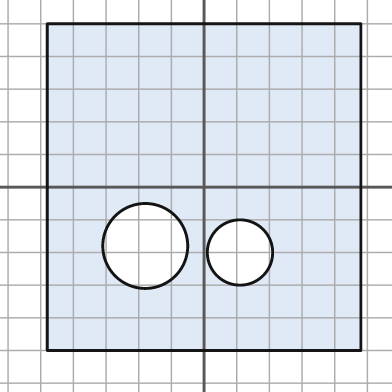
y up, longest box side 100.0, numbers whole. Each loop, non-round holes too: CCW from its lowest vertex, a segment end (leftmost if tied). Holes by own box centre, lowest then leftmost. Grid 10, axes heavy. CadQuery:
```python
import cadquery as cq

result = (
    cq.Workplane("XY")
    .moveTo(-48.0, -50.0)
    .lineTo(48.0, -50.0)
    .lineTo(48.0, 50.0)
    .lineTo(-48.0, 50.0)
    .close()
    .moveTo(11.0, -20.0)
    .circle(10.0)
    .moveTo(-18.0, -18.0)
    .circle(13.0)
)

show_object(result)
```